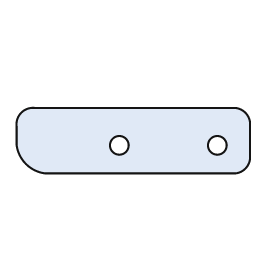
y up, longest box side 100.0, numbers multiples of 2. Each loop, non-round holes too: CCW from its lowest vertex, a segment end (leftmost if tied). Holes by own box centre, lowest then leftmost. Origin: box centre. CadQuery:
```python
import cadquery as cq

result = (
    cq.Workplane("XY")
    .moveTo(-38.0, -14.0)
    .lineTo(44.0, -14.0)
    .threePointArc((48.0, -12.0), (50.0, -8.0))
    .lineTo(50.0, 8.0)
    .threePointArc((48.0, 12.0), (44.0, 14.0))
    .lineTo(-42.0, 14.0)
    .threePointArc((-48.0, 12.0), (-50.0, 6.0))
    .lineTo(-50.0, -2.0)
    .threePointArc((-46.0, -10.0), (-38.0, -14.0))
    .close()
    .moveTo(-6.0, -2.0)
    .circle(4.0)
    .moveTo(36.0, -2.0)
    .circle(4.0)
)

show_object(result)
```